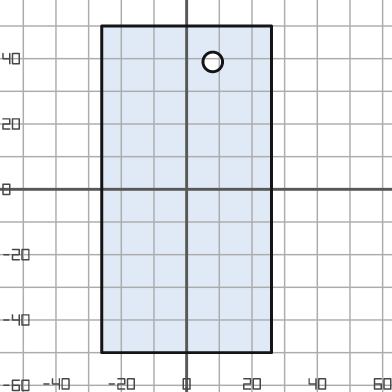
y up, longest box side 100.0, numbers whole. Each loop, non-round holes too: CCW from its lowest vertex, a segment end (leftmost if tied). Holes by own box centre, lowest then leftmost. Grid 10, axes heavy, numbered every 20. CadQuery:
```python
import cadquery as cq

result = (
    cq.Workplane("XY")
    .moveTo(-26.0, -50.0)
    .lineTo(26.0, -50.0)
    .lineTo(26.0, 50.0)
    .lineTo(-26.0, 50.0)
    .close()
    .moveTo(8.0, 39.0)
    .circle(3.0)
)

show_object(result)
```